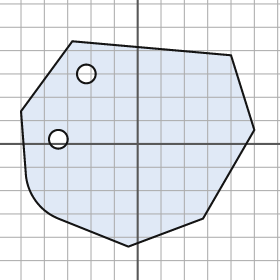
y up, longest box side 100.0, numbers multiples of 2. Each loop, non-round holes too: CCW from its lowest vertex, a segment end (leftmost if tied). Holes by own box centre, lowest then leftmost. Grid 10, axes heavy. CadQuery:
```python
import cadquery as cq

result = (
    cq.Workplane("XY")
    .moveTo(-4.0, -44.0)
    .lineTo(28.0, -32.0)
    .lineTo(50.0, 6.0)
    .lineTo(40.0, 38.0)
    .lineTo(-28.0, 44.0)
    .lineTo(-50.0, 14.0)
    .lineTo(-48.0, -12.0)
    .threePointArc((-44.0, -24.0), (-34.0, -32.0))
    .close()
    .moveTo(-34.0, 2.0)
    .circle(4.0)
    .moveTo(-22.0, 30.0)
    .circle(4.0)
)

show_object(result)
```